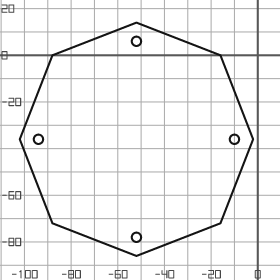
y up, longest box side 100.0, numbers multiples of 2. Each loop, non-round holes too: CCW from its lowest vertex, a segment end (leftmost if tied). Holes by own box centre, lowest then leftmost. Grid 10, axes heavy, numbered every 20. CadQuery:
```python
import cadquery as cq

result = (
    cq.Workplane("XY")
    .moveTo(-52.0, -86.0)
    .lineTo(-16.0, -72.0)
    .lineTo(-2.0, -36.0)
    .lineTo(-16.0, 0.0)
    .lineTo(-52.0, 14.0)
    .lineTo(-88.0, 0.0)
    .lineTo(-102.0, -36.0)
    .lineTo(-88.0, -72.0)
    .close()
    .moveTo(-52.0, -78.0)
    .circle(2.0)
    .moveTo(-94.0, -36.0)
    .circle(2.0)
    .moveTo(-10.0, -36.0)
    .circle(2.0)
    .moveTo(-52.0, 6.0)
    .circle(2.0)
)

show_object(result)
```